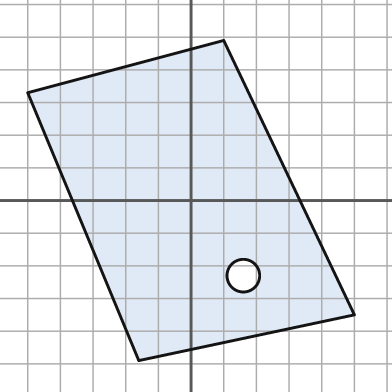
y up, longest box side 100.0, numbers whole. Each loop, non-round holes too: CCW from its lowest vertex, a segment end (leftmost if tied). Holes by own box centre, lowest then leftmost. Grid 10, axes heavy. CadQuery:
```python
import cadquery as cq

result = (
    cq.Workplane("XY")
    .moveTo(-16.0, -49.0)
    .lineTo(50.0, -35.0)
    .lineTo(10.0, 49.0)
    .lineTo(-50.0, 33.0)
    .close()
    .moveTo(16.0, -23.0)
    .circle(5.0)
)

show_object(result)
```